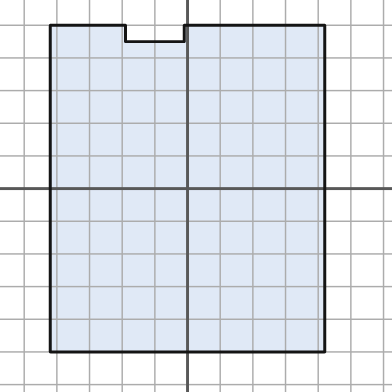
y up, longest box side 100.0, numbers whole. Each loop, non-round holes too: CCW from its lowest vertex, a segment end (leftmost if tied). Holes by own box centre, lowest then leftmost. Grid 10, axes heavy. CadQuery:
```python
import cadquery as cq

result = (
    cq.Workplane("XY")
    .moveTo(-42.0, -50.0)
    .lineTo(42.0, -50.0)
    .lineTo(42.0, 50.0)
    .lineTo(-1.0, 50.0)
    .lineTo(-1.0, 45.0)
    .lineTo(-19.0, 45.0)
    .lineTo(-19.0, 50.0)
    .lineTo(-42.0, 50.0)
    .close()
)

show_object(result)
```